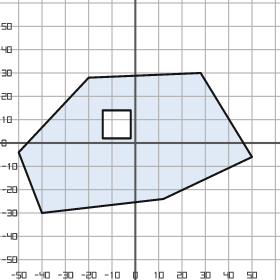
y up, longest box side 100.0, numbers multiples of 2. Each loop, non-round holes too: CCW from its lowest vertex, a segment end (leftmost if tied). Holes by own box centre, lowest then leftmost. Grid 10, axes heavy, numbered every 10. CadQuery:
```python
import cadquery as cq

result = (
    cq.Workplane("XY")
    .moveTo(-40.0, -30.0)
    .lineTo(12.0, -24.0)
    .lineTo(50.0, -6.0)
    .lineTo(28.0, 30.0)
    .lineTo(-20.0, 28.0)
    .lineTo(-50.0, -4.0)
    .close()
    .moveTo(-14.0, 2.0)
    .lineTo(-2.0, 2.0)
    .lineTo(-2.0, 14.0)
    .lineTo(-14.0, 14.0)
    .close()
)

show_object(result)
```